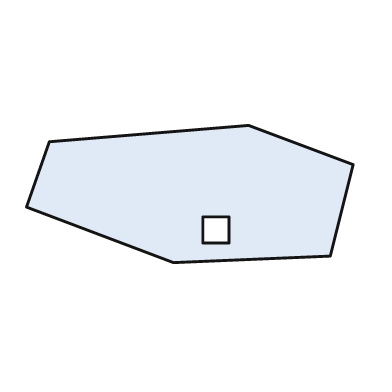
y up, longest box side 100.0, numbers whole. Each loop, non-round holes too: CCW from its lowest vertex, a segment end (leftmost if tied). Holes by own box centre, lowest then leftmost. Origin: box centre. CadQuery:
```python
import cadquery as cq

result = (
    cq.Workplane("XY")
    .moveTo(-5.0, -21.0)
    .lineTo(43.0, -19.0)
    .lineTo(50.0, 9.0)
    .lineTo(18.0, 21.0)
    .lineTo(-43.0, 16.0)
    .lineTo(-50.0, -4.0)
    .close()
    .moveTo(4.0, -15.0)
    .lineTo(12.0, -15.0)
    .lineTo(12.0, -7.0)
    .lineTo(4.0, -7.0)
    .close()
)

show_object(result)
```